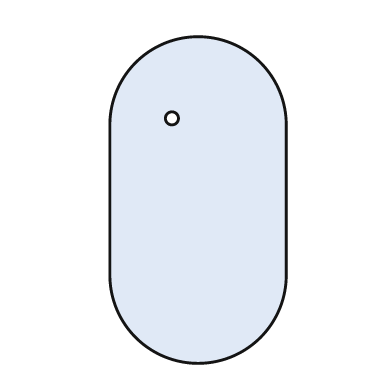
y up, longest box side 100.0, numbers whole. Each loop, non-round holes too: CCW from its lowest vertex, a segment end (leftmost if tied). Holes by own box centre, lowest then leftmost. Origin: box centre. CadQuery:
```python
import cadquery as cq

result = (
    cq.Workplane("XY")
    .moveTo(-27.0, -23.0)
    .threePointArc((0.0, -50.0), (27.0, -23.0))
    .lineTo(27.0, 23.0)
    .threePointArc((0.0, 50.0), (-27.0, 23.0))
    .close()
    .moveTo(-8.0, 25.0)
    .circle(2.0)
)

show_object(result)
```